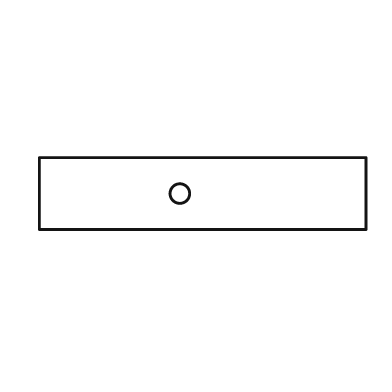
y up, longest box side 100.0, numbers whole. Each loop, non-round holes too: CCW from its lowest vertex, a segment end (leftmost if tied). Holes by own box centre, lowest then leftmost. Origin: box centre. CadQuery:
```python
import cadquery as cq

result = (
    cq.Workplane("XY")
    .moveTo(-50.0, -11.0)
    .lineTo(50.0, -11.0)
    .lineTo(50.0, 11.0)
    .lineTo(-50.0, 11.0)
    .close()
    .moveTo(-7.0, 0.0)
    .circle(3.0)
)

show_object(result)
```